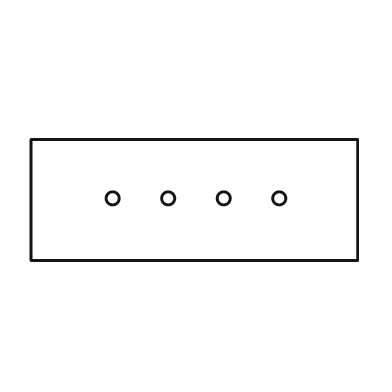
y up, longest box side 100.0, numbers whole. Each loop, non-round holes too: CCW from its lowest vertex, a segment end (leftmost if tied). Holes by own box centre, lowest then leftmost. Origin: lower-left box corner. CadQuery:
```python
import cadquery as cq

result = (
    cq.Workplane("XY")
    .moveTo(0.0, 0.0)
    .lineTo(100.0, 0.0)
    .lineTo(100.0, 37.0)
    .lineTo(0.0, 37.0)
    .close()
    .moveTo(25.0, 19.0)
    .circle(2.0)
    .moveTo(42.0, 19.0)
    .circle(2.0)
    .moveTo(59.0, 19.0)
    .circle(2.0)
    .moveTo(76.0, 19.0)
    .circle(2.0)
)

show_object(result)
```